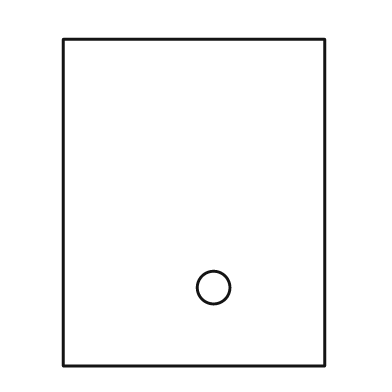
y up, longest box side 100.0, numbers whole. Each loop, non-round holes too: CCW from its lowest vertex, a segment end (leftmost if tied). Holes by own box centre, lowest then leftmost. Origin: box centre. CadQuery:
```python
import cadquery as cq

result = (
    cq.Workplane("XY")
    .moveTo(-40.0, -50.0)
    .lineTo(40.0, -50.0)
    .lineTo(40.0, 50.0)
    .lineTo(-40.0, 50.0)
    .close()
    .moveTo(6.0, -26.0)
    .circle(5.0)
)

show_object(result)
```